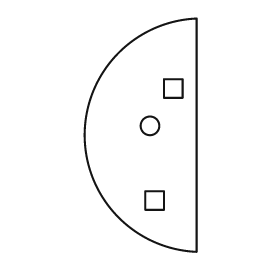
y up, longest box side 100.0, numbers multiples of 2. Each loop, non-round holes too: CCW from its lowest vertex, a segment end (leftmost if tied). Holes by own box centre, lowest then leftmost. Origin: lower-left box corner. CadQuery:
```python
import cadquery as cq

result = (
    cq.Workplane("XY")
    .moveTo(48.0, 0.0)
    .lineTo(48.0, 100.0)
    .threePointArc((0.0, 50.0), (48.0, 0.0))
    .close()
    .moveTo(26.0, 18.0)
    .lineTo(34.0, 18.0)
    .lineTo(34.0, 26.0)
    .lineTo(26.0, 26.0)
    .close()
    .moveTo(28.0, 54.0)
    .circle(4.0)
    .moveTo(34.0, 66.0)
    .lineTo(42.0, 66.0)
    .lineTo(42.0, 74.0)
    .lineTo(34.0, 74.0)
    .close()
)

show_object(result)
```